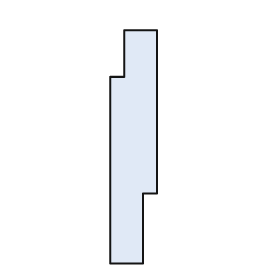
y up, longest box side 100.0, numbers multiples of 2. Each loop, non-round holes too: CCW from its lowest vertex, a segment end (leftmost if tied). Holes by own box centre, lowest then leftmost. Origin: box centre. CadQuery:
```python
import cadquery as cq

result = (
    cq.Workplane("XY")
    .moveTo(-10.0, -50.0)
    .lineTo(4.0, -50.0)
    .lineTo(4.0, -20.0)
    .lineTo(10.0, -20.0)
    .lineTo(10.0, 50.0)
    .lineTo(-4.0, 50.0)
    .lineTo(-4.0, 30.0)
    .lineTo(-10.0, 30.0)
    .close()
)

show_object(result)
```